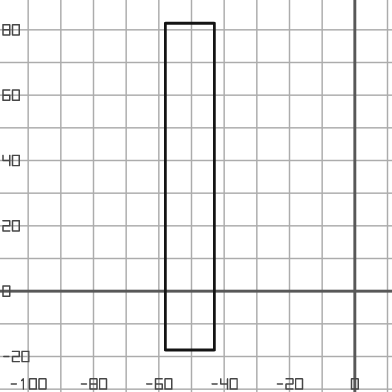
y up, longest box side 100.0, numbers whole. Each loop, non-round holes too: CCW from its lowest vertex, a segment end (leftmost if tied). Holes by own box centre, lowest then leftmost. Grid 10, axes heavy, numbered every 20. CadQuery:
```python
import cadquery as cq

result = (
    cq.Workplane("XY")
    .moveTo(-58.0, -18.0)
    .lineTo(-43.0, -18.0)
    .lineTo(-43.0, 82.0)
    .lineTo(-58.0, 82.0)
    .close()
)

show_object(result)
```